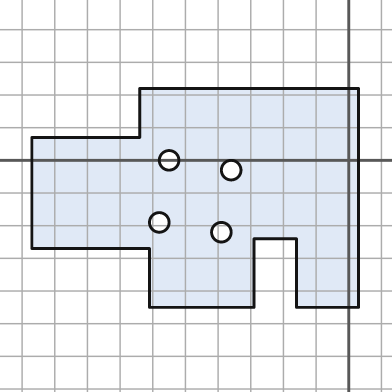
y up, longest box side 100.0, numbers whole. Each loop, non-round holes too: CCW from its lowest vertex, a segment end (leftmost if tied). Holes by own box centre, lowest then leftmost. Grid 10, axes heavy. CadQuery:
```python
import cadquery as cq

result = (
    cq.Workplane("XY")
    .moveTo(-61.0, -45.0)
    .lineTo(-29.0, -45.0)
    .lineTo(-29.0, -24.0)
    .lineTo(-16.0, -24.0)
    .lineTo(-16.0, -45.0)
    .lineTo(3.0, -45.0)
    .lineTo(3.0, 22.0)
    .lineTo(-64.0, 22.0)
    .lineTo(-64.0, 7.0)
    .lineTo(-97.0, 7.0)
    .lineTo(-97.0, -27.0)
    .lineTo(-61.0, -27.0)
    .close()
    .moveTo(-39.0, -22.0)
    .circle(3.0)
    .moveTo(-58.0, -19.0)
    .circle(3.0)
    .moveTo(-36.0, -3.0)
    .circle(3.0)
    .moveTo(-55.0, 0.0)
    .circle(3.0)
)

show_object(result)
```